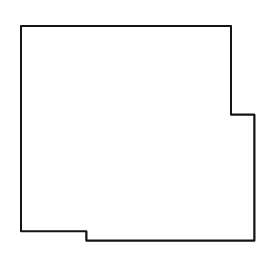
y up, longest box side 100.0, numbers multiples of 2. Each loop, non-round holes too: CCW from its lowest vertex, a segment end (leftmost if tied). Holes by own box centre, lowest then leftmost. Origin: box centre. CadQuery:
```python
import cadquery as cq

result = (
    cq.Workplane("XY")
    .moveTo(-22.0, -46.0)
    .lineTo(50.0, -46.0)
    .lineTo(50.0, 8.0)
    .lineTo(40.0, 8.0)
    .lineTo(40.0, 46.0)
    .lineTo(-50.0, 46.0)
    .lineTo(-50.0, -42.0)
    .lineTo(-22.0, -42.0)
    .close()
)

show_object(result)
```